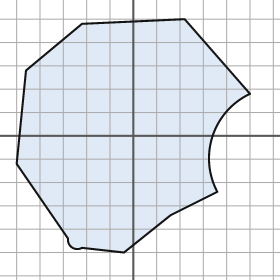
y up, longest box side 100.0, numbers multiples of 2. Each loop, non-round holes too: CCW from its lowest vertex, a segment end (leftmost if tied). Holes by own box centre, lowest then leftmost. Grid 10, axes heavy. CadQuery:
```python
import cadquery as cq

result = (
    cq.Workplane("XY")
    .moveTo(-4.0, -50.0)
    .lineTo(16.0, -34.0)
    .lineTo(36.0, -24.0)
    .threePointArc((34.0, 0.0), (50.0, 18.0))
    .lineTo(22.0, 50.0)
    .lineTo(-22.0, 48.0)
    .lineTo(-46.0, 28.0)
    .lineTo(-50.0, -12.0)
    .lineTo(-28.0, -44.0)
    .threePointArc((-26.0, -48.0), (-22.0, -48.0))
    .close()
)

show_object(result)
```